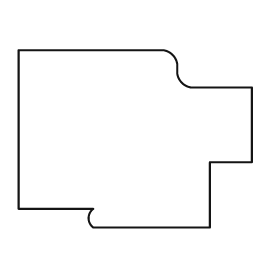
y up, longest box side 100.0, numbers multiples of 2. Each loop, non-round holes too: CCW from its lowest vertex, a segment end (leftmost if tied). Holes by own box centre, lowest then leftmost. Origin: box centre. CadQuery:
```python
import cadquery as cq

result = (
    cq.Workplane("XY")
    .moveTo(-18.0, -38.0)
    .lineTo(32.0, -38.0)
    .lineTo(32.0, -10.0)
    .lineTo(50.0, -10.0)
    .lineTo(50.0, 22.0)
    .lineTo(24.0, 22.0)
    .threePointArc((20.0, 24.0), (18.0, 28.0))
    .lineTo(18.0, 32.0)
    .threePointArc((16.0, 36.0), (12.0, 38.0))
    .lineTo(-50.0, 38.0)
    .lineTo(-50.0, -30.0)
    .lineTo(-18.0, -30.0)
    .threePointArc((-20.0, -34.0), (-18.0, -38.0))
    .close()
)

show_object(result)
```